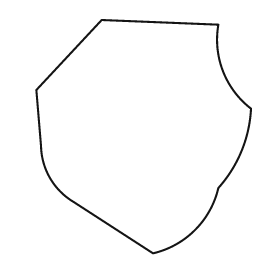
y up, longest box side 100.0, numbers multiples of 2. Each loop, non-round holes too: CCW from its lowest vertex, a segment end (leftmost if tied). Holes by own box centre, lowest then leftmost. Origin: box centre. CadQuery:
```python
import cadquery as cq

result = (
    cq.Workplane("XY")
    .moveTo(4.0, -50.0)
    .threePointArc((22.0, -40.0), (32.0, -22.0))
    .threePointArc((42.0, -6.0), (46.0, 12.0))
    .threePointArc((34.0, 28.0), (32.0, 48.0))
    .lineTo(-18.0, 50.0)
    .lineTo(-46.0, 20.0)
    .lineTo(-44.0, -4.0)
    .threePointArc((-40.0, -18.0), (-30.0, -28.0))
    .close()
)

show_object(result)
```